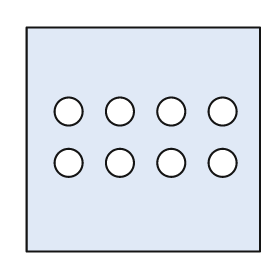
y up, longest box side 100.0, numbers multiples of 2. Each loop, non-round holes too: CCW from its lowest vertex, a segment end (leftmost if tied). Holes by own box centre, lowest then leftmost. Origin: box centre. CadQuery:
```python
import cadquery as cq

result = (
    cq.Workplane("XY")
    .moveTo(-50.0, -48.0)
    .lineTo(50.0, -48.0)
    .lineTo(50.0, 48.0)
    .lineTo(-50.0, 48.0)
    .close()
    .moveTo(-32.0, -10.0)
    .circle(6.0)
    .moveTo(-10.0, -10.0)
    .circle(6.0)
    .moveTo(12.0, -10.0)
    .circle(6.0)
    .moveTo(34.0, -10.0)
    .circle(6.0)
    .moveTo(-32.0, 12.0)
    .circle(6.0)
    .moveTo(-10.0, 12.0)
    .circle(6.0)
    .moveTo(12.0, 12.0)
    .circle(6.0)
    .moveTo(34.0, 12.0)
    .circle(6.0)
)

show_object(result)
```